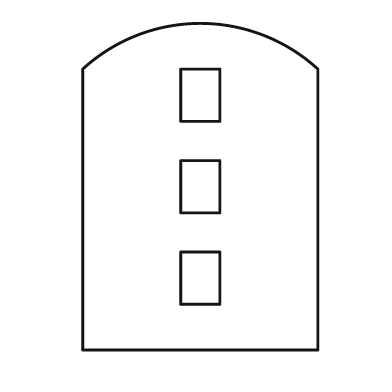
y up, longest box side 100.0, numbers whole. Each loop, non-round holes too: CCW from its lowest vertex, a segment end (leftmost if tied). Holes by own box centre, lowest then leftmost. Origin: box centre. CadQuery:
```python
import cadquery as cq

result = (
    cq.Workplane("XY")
    .moveTo(-36.0, -50.0)
    .lineTo(36.0, -50.0)
    .lineTo(36.0, 36.0)
    .threePointArc((0.0, 50.0), (-36.0, 36.0))
    .close()
    .moveTo(-6.0, -36.0)
    .lineTo(6.0, -36.0)
    .lineTo(6.0, -20.0)
    .lineTo(-6.0, -20.0)
    .close()
    .moveTo(-6.0, -8.0)
    .lineTo(6.0, -8.0)
    .lineTo(6.0, 8.0)
    .lineTo(-6.0, 8.0)
    .close()
    .moveTo(-6.0, 20.0)
    .lineTo(6.0, 20.0)
    .lineTo(6.0, 36.0)
    .lineTo(-6.0, 36.0)
    .close()
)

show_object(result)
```